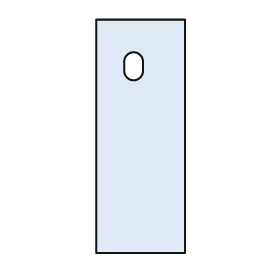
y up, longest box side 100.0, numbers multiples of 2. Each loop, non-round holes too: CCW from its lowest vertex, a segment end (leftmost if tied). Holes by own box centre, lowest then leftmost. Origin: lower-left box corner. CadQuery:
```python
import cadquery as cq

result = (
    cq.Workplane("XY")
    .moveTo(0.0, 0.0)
    .lineTo(38.0, 0.0)
    .lineTo(38.0, 100.0)
    .lineTo(0.0, 100.0)
    .close()
    .moveTo(12.0, 78.0)
    .threePointArc((16.0, 74.0), (20.0, 78.0))
    .lineTo(20.0, 82.0)
    .threePointArc((16.0, 86.0), (12.0, 82.0))
    .close()
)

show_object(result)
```